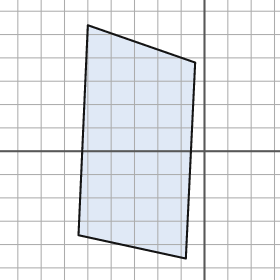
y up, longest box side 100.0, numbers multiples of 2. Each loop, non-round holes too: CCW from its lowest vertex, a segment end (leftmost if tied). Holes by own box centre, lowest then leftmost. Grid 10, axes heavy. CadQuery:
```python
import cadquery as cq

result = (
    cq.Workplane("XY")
    .moveTo(-8.0, -46.0)
    .lineTo(-4.0, 38.0)
    .lineTo(-50.0, 54.0)
    .lineTo(-54.0, -36.0)
    .close()
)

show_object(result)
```